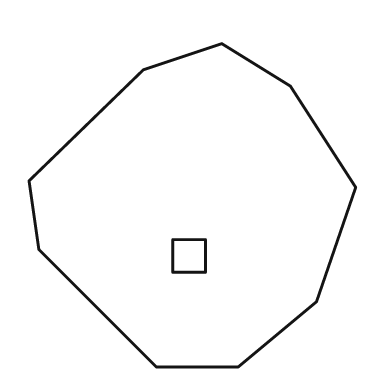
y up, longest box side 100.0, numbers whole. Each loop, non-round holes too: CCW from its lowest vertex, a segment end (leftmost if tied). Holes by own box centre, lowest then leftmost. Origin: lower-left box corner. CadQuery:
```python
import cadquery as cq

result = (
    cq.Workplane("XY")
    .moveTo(39.0, 0.0)
    .lineTo(64.0, 0.0)
    .lineTo(88.0, 20.0)
    .lineTo(100.0, 55.0)
    .lineTo(80.0, 86.0)
    .lineTo(59.0, 99.0)
    .lineTo(35.0, 91.0)
    .lineTo(0.0, 57.0)
    .lineTo(3.0, 36.0)
    .close()
    .moveTo(44.0, 29.0)
    .lineTo(54.0, 29.0)
    .lineTo(54.0, 39.0)
    .lineTo(44.0, 39.0)
    .close()
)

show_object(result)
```